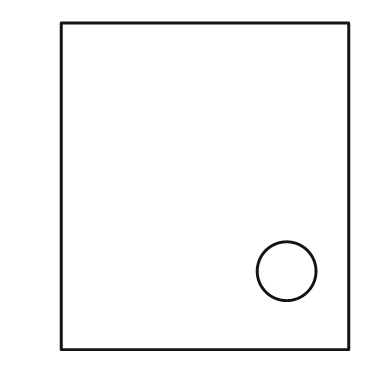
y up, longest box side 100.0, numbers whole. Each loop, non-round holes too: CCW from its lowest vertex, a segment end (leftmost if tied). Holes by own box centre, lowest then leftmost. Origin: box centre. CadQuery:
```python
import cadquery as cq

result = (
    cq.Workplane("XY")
    .moveTo(-44.0, -50.0)
    .lineTo(44.0, -50.0)
    .lineTo(44.0, 50.0)
    .lineTo(-44.0, 50.0)
    .close()
    .moveTo(25.0, -26.0)
    .circle(9.0)
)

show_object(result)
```